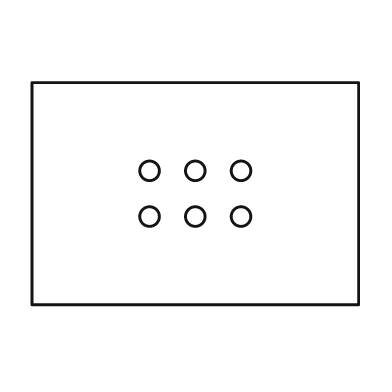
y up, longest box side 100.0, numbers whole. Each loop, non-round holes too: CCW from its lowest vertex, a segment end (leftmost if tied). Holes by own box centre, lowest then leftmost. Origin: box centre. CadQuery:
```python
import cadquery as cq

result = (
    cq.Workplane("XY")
    .moveTo(-50.0, -34.0)
    .lineTo(50.0, -34.0)
    .lineTo(50.0, 34.0)
    .lineTo(-50.0, 34.0)
    .close()
    .moveTo(-14.0, -7.0)
    .circle(3.0)
    .moveTo(0.0, -7.0)
    .circle(3.0)
    .moveTo(14.0, -7.0)
    .circle(3.0)
    .moveTo(-14.0, 7.0)
    .circle(3.0)
    .moveTo(0.0, 7.0)
    .circle(3.0)
    .moveTo(14.0, 7.0)
    .circle(3.0)
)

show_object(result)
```